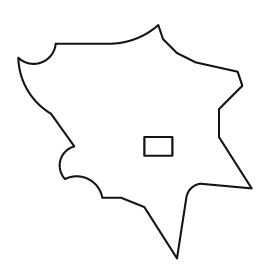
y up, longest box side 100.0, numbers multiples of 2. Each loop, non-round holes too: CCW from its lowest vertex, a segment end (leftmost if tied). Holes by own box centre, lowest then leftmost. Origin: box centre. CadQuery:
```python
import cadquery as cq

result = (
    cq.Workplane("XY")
    .moveTo(18.0, -50.0)
    .lineTo(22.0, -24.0)
    .threePointArc((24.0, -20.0), (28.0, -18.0))
    .lineTo(50.0, -20.0)
    .lineTo(36.0, 2.0)
    .lineTo(36.0, 14.0)
    .lineTo(46.0, 24.0)
    .lineTo(44.0, 30.0)
    .lineTo(26.0, 34.0)
    .lineTo(18.0, 38.0)
    .lineTo(12.0, 44.0)
    .lineTo(10.0, 50.0)
    .threePointArc((0.0, 44.0), (-12.0, 42.0))
    .lineTo(-34.0, 42.0)
    .threePointArc((-40.0, 34.0), (-50.0, 36.0))
    .threePointArc((-46.0, 22.0), (-36.0, 12.0))
    .lineTo(-26.0, -2.0)
    .threePointArc((-32.0, -8.0), (-30.0, -16.0))
    .threePointArc((-20.0, -16.0), (-14.0, -24.0))
    .lineTo(-6.0, -24.0)
    .lineTo(4.0, -28.0)
    .close()
    .moveTo(4.0, -6.0)
    .lineTo(16.0, -6.0)
    .lineTo(16.0, 2.0)
    .lineTo(4.0, 2.0)
    .close()
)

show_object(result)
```